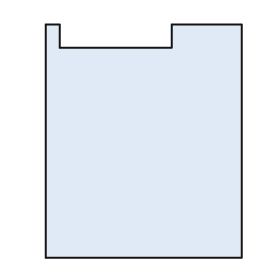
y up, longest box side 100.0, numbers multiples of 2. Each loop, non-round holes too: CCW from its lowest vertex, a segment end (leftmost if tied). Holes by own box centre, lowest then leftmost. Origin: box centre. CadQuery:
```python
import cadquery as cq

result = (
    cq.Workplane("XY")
    .moveTo(-42.0, -50.0)
    .lineTo(42.0, -50.0)
    .lineTo(42.0, 50.0)
    .lineTo(12.0, 50.0)
    .lineTo(12.0, 40.0)
    .lineTo(-36.0, 40.0)
    .lineTo(-36.0, 50.0)
    .lineTo(-42.0, 50.0)
    .close()
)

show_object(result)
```